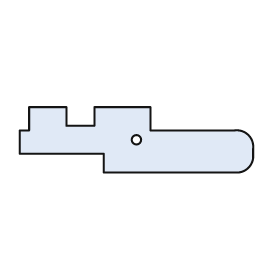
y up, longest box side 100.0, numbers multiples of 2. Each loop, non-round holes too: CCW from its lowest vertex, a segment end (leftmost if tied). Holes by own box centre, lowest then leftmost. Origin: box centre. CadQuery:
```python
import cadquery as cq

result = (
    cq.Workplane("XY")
    .moveTo(-14.0, -14.0)
    .lineTo(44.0, -14.0)
    .threePointArc((48.0, -12.0), (50.0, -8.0))
    .lineTo(50.0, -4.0)
    .threePointArc((48.0, 2.0), (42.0, 4.0))
    .lineTo(6.0, 4.0)
    .lineTo(6.0, 14.0)
    .lineTo(-18.0, 14.0)
    .lineTo(-18.0, 6.0)
    .lineTo(-30.0, 6.0)
    .lineTo(-30.0, 14.0)
    .lineTo(-46.0, 14.0)
    .lineTo(-46.0, 4.0)
    .lineTo(-50.0, 4.0)
    .lineTo(-50.0, -6.0)
    .lineTo(-14.0, -6.0)
    .close()
    .moveTo(0.0, 0.0)
    .circle(2.0)
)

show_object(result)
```